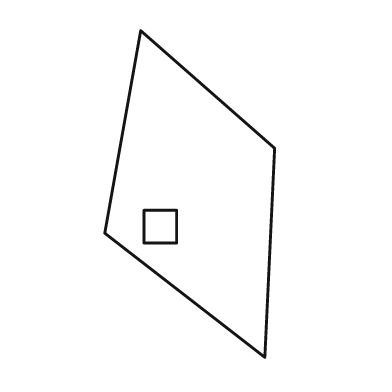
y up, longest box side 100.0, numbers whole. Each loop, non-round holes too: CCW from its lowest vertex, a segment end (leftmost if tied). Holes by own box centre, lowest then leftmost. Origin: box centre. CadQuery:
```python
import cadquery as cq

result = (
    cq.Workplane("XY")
    .moveTo(23.0, -50.0)
    .lineTo(26.0, 14.0)
    .lineTo(-15.0, 50.0)
    .lineTo(-26.0, -12.0)
    .close()
    .moveTo(-14.0, -15.0)
    .lineTo(-4.0, -15.0)
    .lineTo(-4.0, -5.0)
    .lineTo(-14.0, -5.0)
    .close()
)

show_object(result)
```